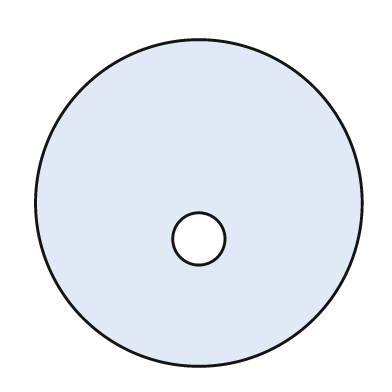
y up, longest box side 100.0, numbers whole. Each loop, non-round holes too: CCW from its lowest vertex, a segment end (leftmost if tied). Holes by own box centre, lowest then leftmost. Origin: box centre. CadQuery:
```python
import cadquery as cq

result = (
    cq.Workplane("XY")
    .moveTo(0.0, 0.0)
    .circle(50.0)
    .moveTo(0.0, -11.0)
    .circle(8.0)
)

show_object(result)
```